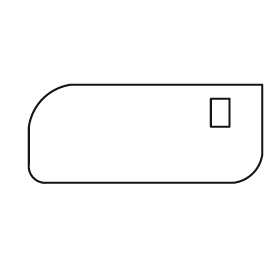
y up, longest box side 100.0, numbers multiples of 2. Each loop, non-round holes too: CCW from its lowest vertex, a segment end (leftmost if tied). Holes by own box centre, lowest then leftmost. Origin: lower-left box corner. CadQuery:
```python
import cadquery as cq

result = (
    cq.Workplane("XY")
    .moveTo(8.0, 0.0)
    .lineTo(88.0, 0.0)
    .threePointArc((96.0, 4.0), (100.0, 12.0))
    .lineTo(100.0, 42.0)
    .lineTo(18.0, 42.0)
    .threePointArc((6.0, 36.0), (0.0, 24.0))
    .lineTo(0.0, 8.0)
    .threePointArc((2.0, 2.0), (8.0, 0.0))
    .close()
    .moveTo(78.0, 24.0)
    .lineTo(86.0, 24.0)
    .lineTo(86.0, 36.0)
    .lineTo(78.0, 36.0)
    .close()
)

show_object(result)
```